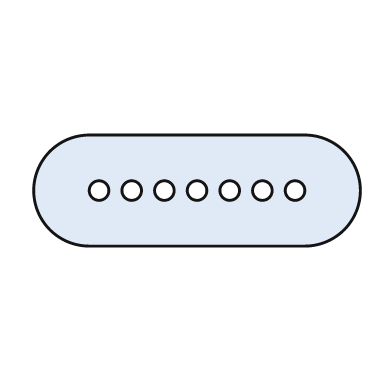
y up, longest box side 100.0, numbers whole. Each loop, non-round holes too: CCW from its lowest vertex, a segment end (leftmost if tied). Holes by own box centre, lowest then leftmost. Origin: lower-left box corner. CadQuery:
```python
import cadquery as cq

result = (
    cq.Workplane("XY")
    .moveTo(17.0, 0.0)
    .lineTo(83.0, 0.0)
    .threePointArc((100.0, 17.0), (83.0, 34.0))
    .lineTo(17.0, 34.0)
    .threePointArc((0.0, 17.0), (17.0, 0.0))
    .close()
    .moveTo(20.0, 17.0)
    .circle(3.0)
    .moveTo(30.0, 17.0)
    .circle(3.0)
    .moveTo(40.0, 17.0)
    .circle(3.0)
    .moveTo(50.0, 17.0)
    .circle(3.0)
    .moveTo(60.0, 17.0)
    .circle(3.0)
    .moveTo(70.0, 17.0)
    .circle(3.0)
    .moveTo(80.0, 17.0)
    .circle(3.0)
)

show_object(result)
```